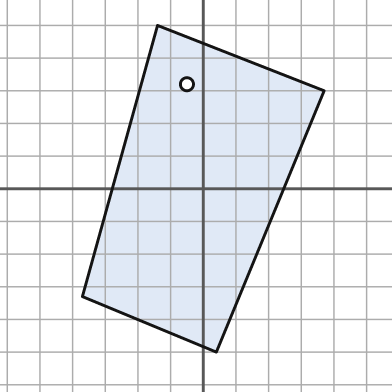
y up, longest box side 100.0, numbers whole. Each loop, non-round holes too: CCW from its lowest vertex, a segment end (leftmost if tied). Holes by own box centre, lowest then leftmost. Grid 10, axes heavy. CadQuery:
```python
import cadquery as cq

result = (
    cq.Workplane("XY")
    .moveTo(4.0, -50.0)
    .lineTo(37.0, 30.0)
    .lineTo(-14.0, 50.0)
    .lineTo(-37.0, -33.0)
    .close()
    .moveTo(-5.0, 32.0)
    .circle(2.0)
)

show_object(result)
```